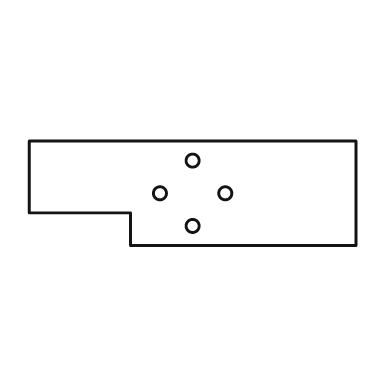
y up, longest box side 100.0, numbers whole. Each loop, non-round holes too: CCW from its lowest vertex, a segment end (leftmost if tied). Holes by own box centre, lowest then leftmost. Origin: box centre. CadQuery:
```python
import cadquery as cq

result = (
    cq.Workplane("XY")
    .moveTo(-19.0, -16.0)
    .lineTo(50.0, -16.0)
    .lineTo(50.0, 16.0)
    .lineTo(-50.0, 16.0)
    .lineTo(-50.0, -6.0)
    .lineTo(-19.0, -6.0)
    .close()
    .moveTo(0.0, -10.0)
    .circle(2.0)
    .moveTo(-10.0, 0.0)
    .circle(2.0)
    .moveTo(10.0, 0.0)
    .circle(2.0)
    .moveTo(0.0, 10.0)
    .circle(2.0)
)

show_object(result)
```